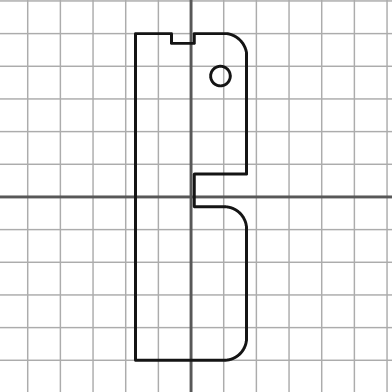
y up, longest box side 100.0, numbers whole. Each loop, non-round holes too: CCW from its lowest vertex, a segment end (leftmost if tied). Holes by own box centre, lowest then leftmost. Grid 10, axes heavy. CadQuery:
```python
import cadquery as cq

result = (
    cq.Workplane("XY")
    .moveTo(-17.0, -50.0)
    .lineTo(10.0, -50.0)
    .threePointArc((15.0, -48.0), (17.0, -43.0))
    .lineTo(17.0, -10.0)
    .threePointArc((15.0, -5.0), (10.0, -3.0))
    .lineTo(1.0, -3.0)
    .lineTo(1.0, 7.0)
    .lineTo(17.0, 7.0)
    .lineTo(17.0, 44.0)
    .threePointArc((15.0, 48.0), (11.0, 50.0))
    .lineTo(1.0, 50.0)
    .lineTo(1.0, 47.0)
    .lineTo(-6.0, 47.0)
    .lineTo(-6.0, 50.0)
    .lineTo(-17.0, 50.0)
    .close()
    .moveTo(9.0, 37.0)
    .circle(3.0)
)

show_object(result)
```